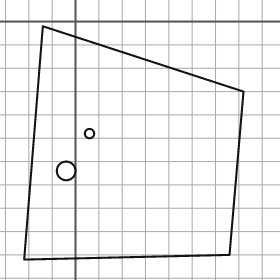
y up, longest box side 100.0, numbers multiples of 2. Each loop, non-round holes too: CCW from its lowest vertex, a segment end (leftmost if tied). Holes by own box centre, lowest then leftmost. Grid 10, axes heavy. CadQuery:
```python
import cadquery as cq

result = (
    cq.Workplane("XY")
    .moveTo(-22.0, -102.0)
    .lineTo(66.0, -100.0)
    .lineTo(72.0, -30.0)
    .lineTo(-14.0, -2.0)
    .close()
    .moveTo(-4.0, -64.0)
    .circle(4.0)
    .moveTo(6.0, -48.0)
    .circle(2.0)
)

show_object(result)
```